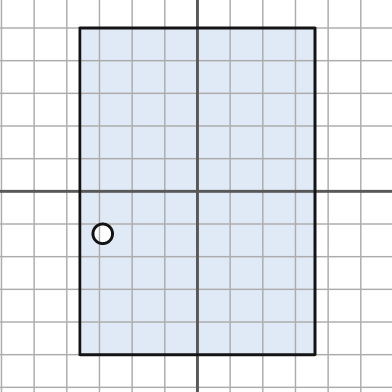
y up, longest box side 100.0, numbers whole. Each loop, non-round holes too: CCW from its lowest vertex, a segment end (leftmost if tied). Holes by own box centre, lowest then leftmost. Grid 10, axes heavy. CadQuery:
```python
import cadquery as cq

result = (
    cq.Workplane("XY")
    .moveTo(-36.0, -50.0)
    .lineTo(36.0, -50.0)
    .lineTo(36.0, 50.0)
    .lineTo(-36.0, 50.0)
    .close()
    .moveTo(-29.0, -13.0)
    .circle(3.0)
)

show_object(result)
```